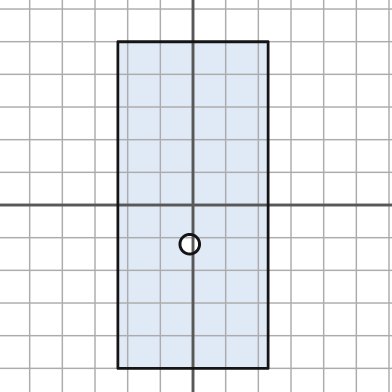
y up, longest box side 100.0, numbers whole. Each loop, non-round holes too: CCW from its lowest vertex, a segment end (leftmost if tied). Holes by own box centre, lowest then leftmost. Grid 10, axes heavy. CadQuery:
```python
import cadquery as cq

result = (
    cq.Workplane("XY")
    .moveTo(-23.0, -50.0)
    .lineTo(23.0, -50.0)
    .lineTo(23.0, 50.0)
    .lineTo(-23.0, 50.0)
    .close()
    .moveTo(-1.0, -12.0)
    .circle(3.0)
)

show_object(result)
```